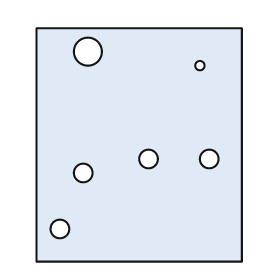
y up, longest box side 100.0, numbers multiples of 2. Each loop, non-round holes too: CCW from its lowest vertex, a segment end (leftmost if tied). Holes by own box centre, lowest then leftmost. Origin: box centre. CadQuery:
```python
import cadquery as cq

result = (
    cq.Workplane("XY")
    .moveTo(-44.0, -50.0)
    .lineTo(44.0, -50.0)
    .lineTo(44.0, 50.0)
    .lineTo(-44.0, 50.0)
    .close()
    .moveTo(-34.0, -36.0)
    .circle(4.0)
    .moveTo(-24.0, -12.0)
    .circle(4.0)
    .moveTo(4.0, -6.0)
    .circle(4.0)
    .moveTo(30.0, -6.0)
    .circle(4.0)
    .moveTo(26.0, 34.0)
    .circle(2.0)
    .moveTo(-22.0, 40.0)
    .circle(6.0)
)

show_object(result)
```